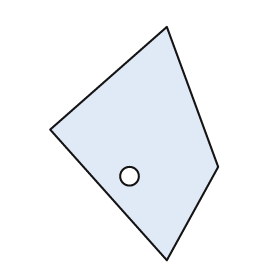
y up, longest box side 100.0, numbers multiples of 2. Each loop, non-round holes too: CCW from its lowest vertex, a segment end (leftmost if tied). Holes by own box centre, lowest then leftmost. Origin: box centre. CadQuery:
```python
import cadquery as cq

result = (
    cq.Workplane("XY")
    .moveTo(14.0, -50.0)
    .lineTo(36.0, -10.0)
    .lineTo(14.0, 50.0)
    .lineTo(-36.0, 6.0)
    .close()
    .moveTo(-2.0, -14.0)
    .circle(4.0)
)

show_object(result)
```